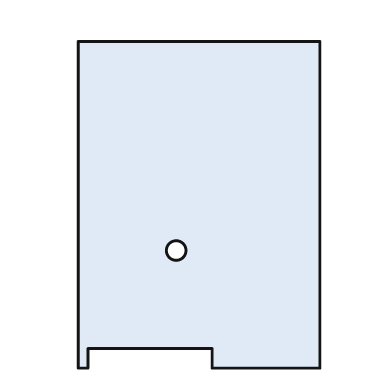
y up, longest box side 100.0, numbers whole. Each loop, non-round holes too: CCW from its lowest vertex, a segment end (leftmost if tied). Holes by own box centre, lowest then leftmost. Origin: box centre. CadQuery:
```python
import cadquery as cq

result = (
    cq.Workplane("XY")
    .moveTo(-37.0, -50.0)
    .lineTo(-34.0, -50.0)
    .lineTo(-34.0, -44.0)
    .lineTo(4.0, -44.0)
    .lineTo(4.0, -50.0)
    .lineTo(37.0, -50.0)
    .lineTo(37.0, 50.0)
    .lineTo(-37.0, 50.0)
    .close()
    .moveTo(-7.0, -14.0)
    .circle(3.0)
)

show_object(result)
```